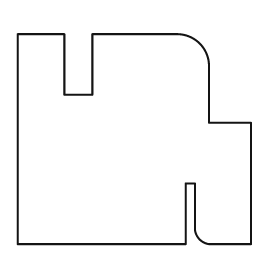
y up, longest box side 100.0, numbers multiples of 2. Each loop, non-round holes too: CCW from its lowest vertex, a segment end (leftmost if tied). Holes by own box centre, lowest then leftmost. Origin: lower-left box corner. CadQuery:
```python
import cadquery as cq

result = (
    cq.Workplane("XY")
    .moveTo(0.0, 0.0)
    .lineTo(72.0, 0.0)
    .lineTo(72.0, 26.0)
    .lineTo(76.0, 26.0)
    .lineTo(76.0, 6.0)
    .threePointArc((78.0, 2.0), (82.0, 0.0))
    .lineTo(100.0, 0.0)
    .lineTo(100.0, 52.0)
    .lineTo(82.0, 52.0)
    .lineTo(82.0, 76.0)
    .threePointArc((78.0, 86.0), (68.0, 90.0))
    .lineTo(32.0, 90.0)
    .lineTo(32.0, 64.0)
    .lineTo(20.0, 64.0)
    .lineTo(20.0, 90.0)
    .lineTo(0.0, 90.0)
    .close()
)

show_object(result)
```